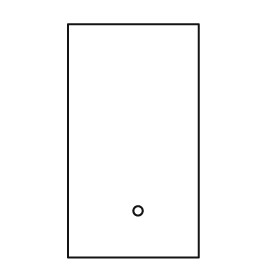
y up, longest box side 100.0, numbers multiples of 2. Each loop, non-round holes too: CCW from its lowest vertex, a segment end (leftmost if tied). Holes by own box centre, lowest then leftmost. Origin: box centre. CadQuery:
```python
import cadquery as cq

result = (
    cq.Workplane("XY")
    .moveTo(-28.0, -50.0)
    .lineTo(28.0, -50.0)
    .lineTo(28.0, 50.0)
    .lineTo(-28.0, 50.0)
    .close()
    .moveTo(2.0, -30.0)
    .circle(2.0)
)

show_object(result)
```